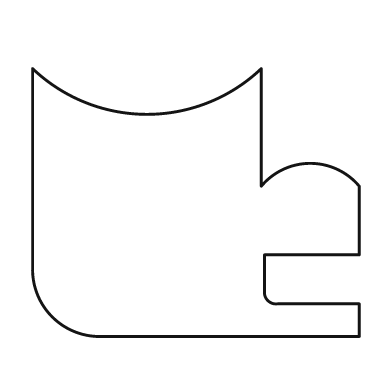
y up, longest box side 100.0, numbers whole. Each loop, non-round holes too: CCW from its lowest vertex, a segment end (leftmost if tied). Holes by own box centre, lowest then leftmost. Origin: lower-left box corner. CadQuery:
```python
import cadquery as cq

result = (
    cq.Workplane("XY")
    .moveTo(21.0, 0.0)
    .lineTo(100.0, 0.0)
    .lineTo(100.0, 10.0)
    .lineTo(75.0, 10.0)
    .threePointArc((72.0, 11.0), (71.0, 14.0))
    .lineTo(71.0, 25.0)
    .lineTo(100.0, 25.0)
    .lineTo(100.0, 46.0)
    .threePointArc((85.0, 53.0), (70.0, 46.0))
    .lineTo(70.0, 82.0)
    .threePointArc((35.0, 68.0), (0.0, 82.0))
    .lineTo(0.0, 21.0)
    .threePointArc((6.0, 6.0), (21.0, 0.0))
    .close()
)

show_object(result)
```